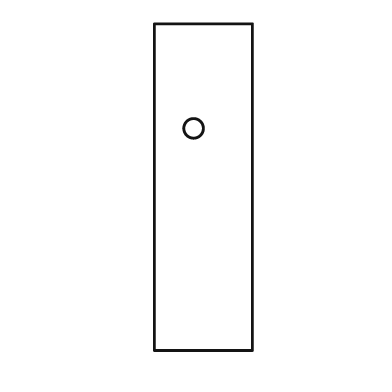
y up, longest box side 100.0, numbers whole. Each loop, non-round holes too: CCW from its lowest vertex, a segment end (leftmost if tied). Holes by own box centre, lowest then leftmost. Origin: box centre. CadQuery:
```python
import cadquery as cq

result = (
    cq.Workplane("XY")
    .moveTo(-15.0, -50.0)
    .lineTo(15.0, -50.0)
    .lineTo(15.0, 50.0)
    .lineTo(-15.0, 50.0)
    .close()
    .moveTo(-3.0, 18.0)
    .circle(3.0)
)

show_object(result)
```